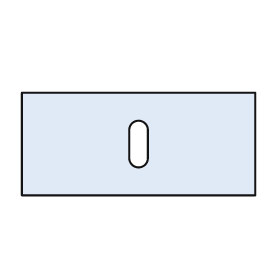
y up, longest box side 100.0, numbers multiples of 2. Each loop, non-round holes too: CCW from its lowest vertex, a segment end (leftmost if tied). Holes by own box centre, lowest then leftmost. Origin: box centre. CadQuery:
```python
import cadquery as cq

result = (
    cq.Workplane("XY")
    .moveTo(-50.0, -22.0)
    .lineTo(50.0, -22.0)
    .lineTo(50.0, 22.0)
    .lineTo(-50.0, 22.0)
    .close()
    .moveTo(-4.0, -6.0)
    .threePointArc((0.0, -10.0), (4.0, -6.0))
    .lineTo(4.0, 6.0)
    .threePointArc((0.0, 10.0), (-4.0, 6.0))
    .close()
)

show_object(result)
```